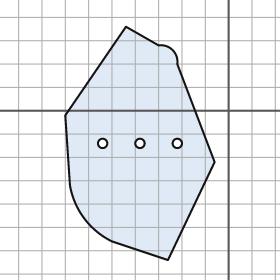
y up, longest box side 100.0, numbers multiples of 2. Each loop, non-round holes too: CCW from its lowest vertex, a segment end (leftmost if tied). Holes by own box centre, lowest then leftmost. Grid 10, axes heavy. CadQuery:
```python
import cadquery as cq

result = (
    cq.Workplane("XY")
    .moveTo(-26.0, -64.0)
    .lineTo(-6.0, -22.0)
    .lineTo(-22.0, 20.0)
    .threePointArc((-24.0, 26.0), (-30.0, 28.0))
    .lineTo(-44.0, 36.0)
    .lineTo(-70.0, -2.0)
    .lineTo(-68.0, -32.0)
    .threePointArc((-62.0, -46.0), (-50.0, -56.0))
    .close()
    .moveTo(-54.0, -14.0)
    .circle(2.0)
    .moveTo(-38.0, -14.0)
    .circle(2.0)
    .moveTo(-22.0, -14.0)
    .circle(2.0)
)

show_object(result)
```